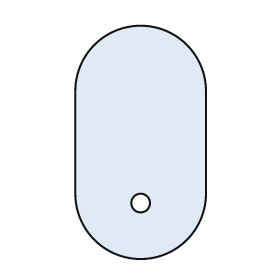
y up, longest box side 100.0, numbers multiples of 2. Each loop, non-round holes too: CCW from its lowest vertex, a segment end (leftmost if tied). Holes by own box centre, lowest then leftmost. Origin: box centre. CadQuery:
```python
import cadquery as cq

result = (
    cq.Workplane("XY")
    .moveTo(-28.0, -22.0)
    .threePointArc((0.0, -50.0), (28.0, -22.0))
    .lineTo(28.0, 22.0)
    .threePointArc((0.0, 50.0), (-28.0, 22.0))
    .close()
    .moveTo(0.0, -26.0)
    .circle(4.0)
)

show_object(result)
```